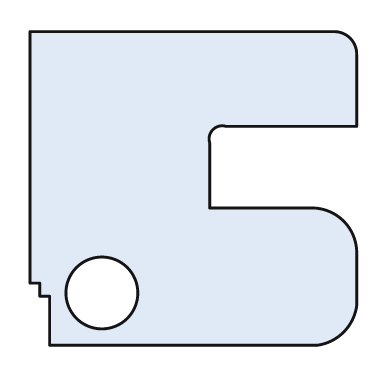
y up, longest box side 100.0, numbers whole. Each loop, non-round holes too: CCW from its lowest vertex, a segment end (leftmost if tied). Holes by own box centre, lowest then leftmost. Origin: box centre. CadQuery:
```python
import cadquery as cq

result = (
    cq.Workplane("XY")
    .moveTo(-44.0, -48.0)
    .lineTo(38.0, -48.0)
    .threePointArc((46.0, -44.0), (50.0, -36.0))
    .lineTo(50.0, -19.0)
    .threePointArc((46.0, -10.0), (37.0, -6.0))
    .lineTo(5.0, -6.0)
    .lineTo(5.0, 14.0)
    .threePointArc((6.0, 18.0), (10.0, 19.0))
    .lineTo(50.0, 19.0)
    .lineTo(50.0, 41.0)
    .threePointArc((48.0, 46.0), (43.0, 48.0))
    .lineTo(-50.0, 48.0)
    .lineTo(-50.0, -29.0)
    .lineTo(-47.0, -29.0)
    .lineTo(-47.0, -33.0)
    .lineTo(-44.0, -33.0)
    .close()
    .moveTo(-28.0, -32.0)
    .circle(11.0)
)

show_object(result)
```